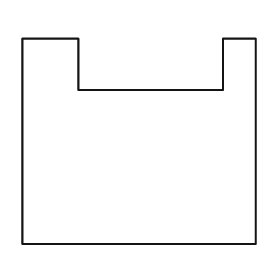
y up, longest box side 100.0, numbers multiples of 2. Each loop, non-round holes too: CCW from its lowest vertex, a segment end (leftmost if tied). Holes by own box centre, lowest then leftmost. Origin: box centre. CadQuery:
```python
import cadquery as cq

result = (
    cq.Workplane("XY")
    .moveTo(-50.0, -44.0)
    .lineTo(50.0, -44.0)
    .lineTo(50.0, 44.0)
    .lineTo(36.0, 44.0)
    .lineTo(36.0, 22.0)
    .lineTo(-26.0, 22.0)
    .lineTo(-26.0, 44.0)
    .lineTo(-50.0, 44.0)
    .close()
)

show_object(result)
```